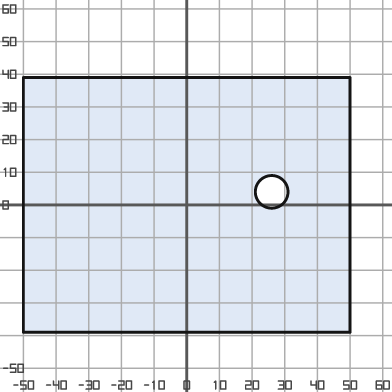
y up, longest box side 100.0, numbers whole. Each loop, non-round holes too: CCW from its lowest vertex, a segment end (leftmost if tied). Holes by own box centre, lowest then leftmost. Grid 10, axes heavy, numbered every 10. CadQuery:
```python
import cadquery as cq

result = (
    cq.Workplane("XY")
    .moveTo(-50.0, -39.0)
    .lineTo(50.0, -39.0)
    .lineTo(50.0, 39.0)
    .lineTo(-50.0, 39.0)
    .close()
    .moveTo(26.0, 4.0)
    .circle(5.0)
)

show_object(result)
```